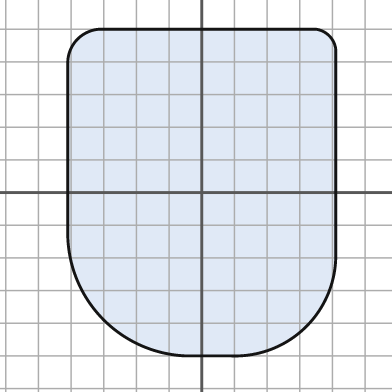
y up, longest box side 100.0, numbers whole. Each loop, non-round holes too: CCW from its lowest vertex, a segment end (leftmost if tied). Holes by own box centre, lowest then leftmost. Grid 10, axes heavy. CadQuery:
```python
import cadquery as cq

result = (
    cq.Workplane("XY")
    .moveTo(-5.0, -50.0)
    .lineTo(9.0, -50.0)
    .threePointArc((32.0, -41.0), (41.0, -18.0))
    .lineTo(41.0, 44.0)
    .threePointArc((39.0, 48.0), (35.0, 50.0))
    .lineTo(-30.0, 50.0)
    .threePointArc((-38.0, 47.0), (-41.0, 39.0))
    .lineTo(-41.0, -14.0)
    .threePointArc((-30.0, -39.0), (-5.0, -50.0))
    .close()
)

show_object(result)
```